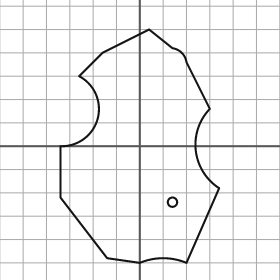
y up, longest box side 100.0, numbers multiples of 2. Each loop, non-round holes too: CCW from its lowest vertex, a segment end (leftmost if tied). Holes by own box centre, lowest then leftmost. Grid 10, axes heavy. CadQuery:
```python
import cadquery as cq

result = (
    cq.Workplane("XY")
    .moveTo(0.0, -50.0)
    .threePointArc((10.0, -48.0), (20.0, -50.0))
    .lineTo(34.0, -18.0)
    .threePointArc((24.0, -2.0), (30.0, 16.0))
    .lineTo(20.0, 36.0)
    .threePointArc((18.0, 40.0), (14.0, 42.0))
    .lineTo(4.0, 50.0)
    .lineTo(-16.0, 40.0)
    .lineTo(-26.0, 30.0)
    .threePointArc((-18.0, 12.0), (-34.0, 0.0))
    .lineTo(-34.0, -22.0)
    .lineTo(-14.0, -48.0)
    .close()
    .moveTo(14.0, -24.0)
    .circle(2.0)
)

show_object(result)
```